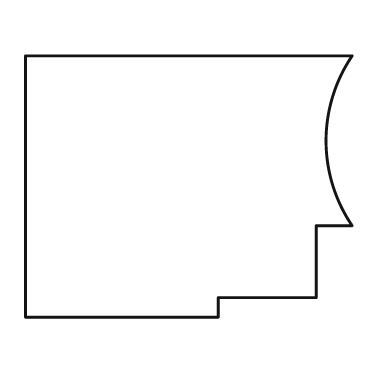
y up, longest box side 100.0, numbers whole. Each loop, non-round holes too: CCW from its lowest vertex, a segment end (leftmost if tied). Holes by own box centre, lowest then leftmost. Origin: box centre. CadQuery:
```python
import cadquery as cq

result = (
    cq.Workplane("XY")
    .moveTo(-50.0, -40.0)
    .lineTo(9.0, -40.0)
    .lineTo(9.0, -34.0)
    .lineTo(39.0, -34.0)
    .lineTo(39.0, -12.0)
    .lineTo(50.0, -12.0)
    .threePointArc((42.0, 14.0), (50.0, 40.0))
    .lineTo(-50.0, 40.0)
    .close()
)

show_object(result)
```